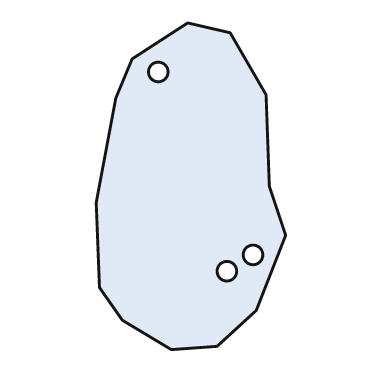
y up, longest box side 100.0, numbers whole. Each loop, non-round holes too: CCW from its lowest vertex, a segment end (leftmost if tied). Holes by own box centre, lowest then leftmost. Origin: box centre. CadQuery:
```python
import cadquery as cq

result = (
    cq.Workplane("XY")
    .moveTo(-6.0, -50.0)
    .lineTo(8.0, -49.0)
    .lineTo(20.0, -38.0)
    .lineTo(29.0, -15.0)
    .lineTo(24.0, 0.0)
    .lineTo(23.0, 28.0)
    .lineTo(12.0, 47.0)
    .lineTo(-1.0, 50.0)
    .lineTo(-18.0, 39.0)
    .lineTo(-23.0, 27.0)
    .lineTo(-29.0, -5.0)
    .lineTo(-28.0, -31.0)
    .lineTo(-21.0, -41.0)
    .close()
    .moveTo(11.0, -26.0)
    .circle(3.0)
    .moveTo(19.0, -21.0)
    .circle(3.0)
    .moveTo(-10.0, 35.0)
    .circle(3.0)
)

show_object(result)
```